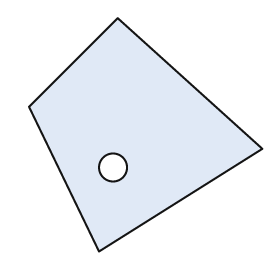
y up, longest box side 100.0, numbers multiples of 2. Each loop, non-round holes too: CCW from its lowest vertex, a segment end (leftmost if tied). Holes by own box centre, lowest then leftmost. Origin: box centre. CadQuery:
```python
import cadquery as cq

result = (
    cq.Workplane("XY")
    .moveTo(-20.0, -50.0)
    .lineTo(50.0, -6.0)
    .lineTo(-12.0, 50.0)
    .lineTo(-50.0, 12.0)
    .close()
    .moveTo(-14.0, -14.0)
    .circle(6.0)
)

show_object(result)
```